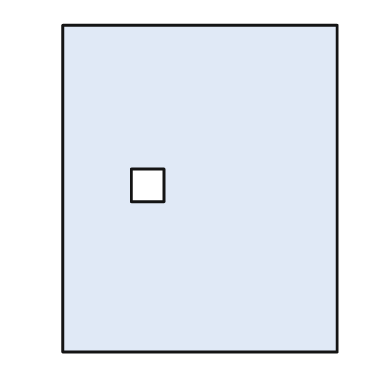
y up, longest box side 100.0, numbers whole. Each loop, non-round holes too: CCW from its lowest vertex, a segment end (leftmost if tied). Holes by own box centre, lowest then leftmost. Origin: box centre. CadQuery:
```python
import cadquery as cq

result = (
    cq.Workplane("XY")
    .moveTo(-42.0, -50.0)
    .lineTo(42.0, -50.0)
    .lineTo(42.0, 50.0)
    .lineTo(-42.0, 50.0)
    .close()
    .moveTo(-21.0, -4.0)
    .lineTo(-11.0, -4.0)
    .lineTo(-11.0, 6.0)
    .lineTo(-21.0, 6.0)
    .close()
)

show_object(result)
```